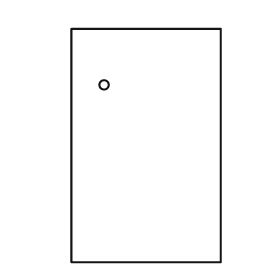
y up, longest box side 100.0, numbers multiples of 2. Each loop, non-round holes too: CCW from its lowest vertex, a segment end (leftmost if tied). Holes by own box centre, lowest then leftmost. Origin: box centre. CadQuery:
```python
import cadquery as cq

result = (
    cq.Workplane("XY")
    .moveTo(-32.0, -50.0)
    .lineTo(32.0, -50.0)
    .lineTo(32.0, 50.0)
    .lineTo(-32.0, 50.0)
    .close()
    .moveTo(-18.0, 26.0)
    .circle(2.0)
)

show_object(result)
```